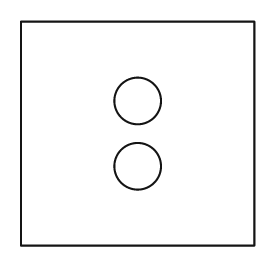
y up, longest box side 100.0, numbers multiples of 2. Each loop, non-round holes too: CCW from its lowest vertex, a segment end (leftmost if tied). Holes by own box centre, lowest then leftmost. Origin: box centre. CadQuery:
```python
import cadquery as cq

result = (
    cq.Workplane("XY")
    .moveTo(-50.0, -48.0)
    .lineTo(50.0, -48.0)
    .lineTo(50.0, 48.0)
    .lineTo(-50.0, 48.0)
    .close()
    .moveTo(0.0, -14.0)
    .circle(10.0)
    .moveTo(0.0, 14.0)
    .circle(10.0)
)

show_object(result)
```